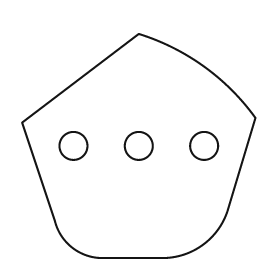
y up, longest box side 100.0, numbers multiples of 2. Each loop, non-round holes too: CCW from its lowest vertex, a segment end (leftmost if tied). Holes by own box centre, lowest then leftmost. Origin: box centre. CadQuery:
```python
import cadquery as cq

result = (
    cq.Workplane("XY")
    .moveTo(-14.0, -48.0)
    .lineTo(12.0, -48.0)
    .threePointArc((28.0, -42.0), (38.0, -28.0))
    .lineTo(50.0, 12.0)
    .threePointArc((28.0, 34.0), (0.0, 48.0))
    .lineTo(-50.0, 10.0)
    .lineTo(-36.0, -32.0)
    .threePointArc((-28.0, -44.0), (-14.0, -48.0))
    .close()
    .moveTo(-28.0, 0.0)
    .circle(6.0)
    .moveTo(0.0, 0.0)
    .circle(6.0)
    .moveTo(28.0, 0.0)
    .circle(6.0)
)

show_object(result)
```